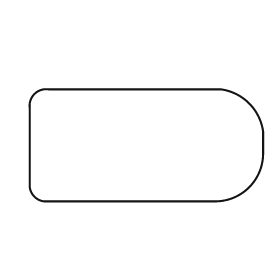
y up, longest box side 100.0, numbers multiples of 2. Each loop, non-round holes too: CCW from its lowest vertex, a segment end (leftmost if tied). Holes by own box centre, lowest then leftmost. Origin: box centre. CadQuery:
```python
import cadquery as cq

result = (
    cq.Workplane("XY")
    .moveTo(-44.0, -24.0)
    .lineTo(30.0, -24.0)
    .threePointArc((44.0, -18.0), (50.0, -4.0))
    .lineTo(50.0, 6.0)
    .threePointArc((44.0, 18.0), (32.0, 24.0))
    .lineTo(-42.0, 24.0)
    .threePointArc((-48.0, 22.0), (-50.0, 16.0))
    .lineTo(-50.0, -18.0)
    .threePointArc((-48.0, -22.0), (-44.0, -24.0))
    .close()
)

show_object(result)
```